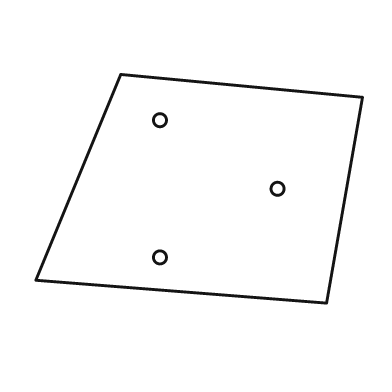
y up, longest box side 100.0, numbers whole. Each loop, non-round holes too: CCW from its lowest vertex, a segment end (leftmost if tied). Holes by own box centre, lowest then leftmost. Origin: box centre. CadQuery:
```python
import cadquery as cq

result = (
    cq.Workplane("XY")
    .moveTo(39.0, -35.0)
    .lineTo(50.0, 28.0)
    .lineTo(-24.0, 35.0)
    .lineTo(-50.0, -28.0)
    .close()
    .moveTo(-12.0, -21.0)
    .circle(2.0)
    .moveTo(24.0, 0.0)
    .circle(2.0)
    .moveTo(-12.0, 21.0)
    .circle(2.0)
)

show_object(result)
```